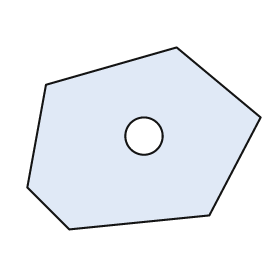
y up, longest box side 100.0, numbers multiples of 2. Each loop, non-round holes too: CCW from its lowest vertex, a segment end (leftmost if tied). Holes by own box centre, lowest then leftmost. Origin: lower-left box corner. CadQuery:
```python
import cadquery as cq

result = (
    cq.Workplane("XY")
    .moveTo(18.0, 0.0)
    .lineTo(78.0, 6.0)
    .lineTo(100.0, 48.0)
    .lineTo(64.0, 78.0)
    .lineTo(8.0, 62.0)
    .lineTo(0.0, 18.0)
    .close()
    .moveTo(50.0, 40.0)
    .circle(8.0)
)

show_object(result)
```